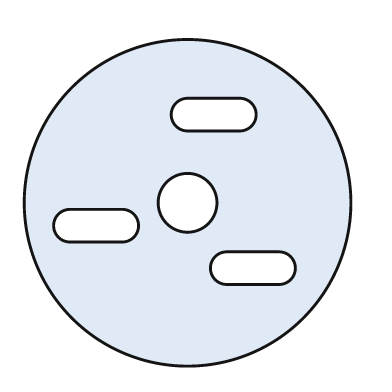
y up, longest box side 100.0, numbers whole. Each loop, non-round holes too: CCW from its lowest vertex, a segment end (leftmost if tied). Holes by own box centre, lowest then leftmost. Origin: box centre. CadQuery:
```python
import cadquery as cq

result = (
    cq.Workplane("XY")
    .moveTo(0.0, 0.0)
    .circle(50.0)
    .moveTo(12.0, -25.0)
    .lineTo(28.0, -25.0)
    .threePointArc((33.0, -20.0), (28.0, -15.0))
    .lineTo(12.0, -15.0)
    .threePointArc((7.0, -20.0), (12.0, -25.0))
    .close()
    .moveTo(-36.0, -12.0)
    .lineTo(-20.0, -12.0)
    .threePointArc((-15.0, -7.0), (-20.0, -2.0))
    .lineTo(-36.0, -2.0)
    .threePointArc((-41.0, -7.0), (-36.0, -12.0))
    .close()
    .moveTo(0.0, 0.0)
    .circle(9.0)
    .moveTo(0.0, 22.0)
    .lineTo(16.0, 22.0)
    .threePointArc((21.0, 27.0), (16.0, 32.0))
    .lineTo(0.0, 32.0)
    .threePointArc((-5.0, 27.0), (0.0, 22.0))
    .close()
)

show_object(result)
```